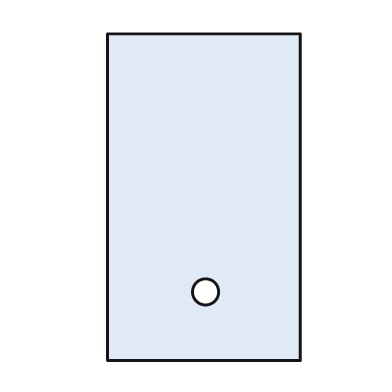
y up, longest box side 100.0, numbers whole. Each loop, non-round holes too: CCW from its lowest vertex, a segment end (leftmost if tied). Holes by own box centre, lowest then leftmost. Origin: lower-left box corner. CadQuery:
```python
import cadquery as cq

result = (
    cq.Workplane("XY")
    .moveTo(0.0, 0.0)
    .lineTo(59.0, 0.0)
    .lineTo(59.0, 100.0)
    .lineTo(0.0, 100.0)
    .close()
    .moveTo(30.0, 21.0)
    .circle(4.0)
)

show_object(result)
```